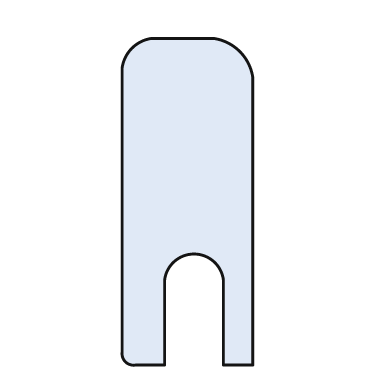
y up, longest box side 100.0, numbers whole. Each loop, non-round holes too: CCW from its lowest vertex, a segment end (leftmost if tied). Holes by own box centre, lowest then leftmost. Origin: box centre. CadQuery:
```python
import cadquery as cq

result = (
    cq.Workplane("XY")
    .moveTo(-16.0, -50.0)
    .lineTo(-7.0, -50.0)
    .lineTo(-7.0, -24.0)
    .threePointArc((2.0, -16.0), (11.0, -24.0))
    .lineTo(11.0, -50.0)
    .lineTo(20.0, -50.0)
    .lineTo(20.0, 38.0)
    .threePointArc((16.0, 46.0), (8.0, 50.0))
    .lineTo(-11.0, 50.0)
    .threePointArc((-17.0, 47.0), (-20.0, 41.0))
    .lineTo(-20.0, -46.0)
    .threePointArc((-19.0, -49.0), (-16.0, -50.0))
    .close()
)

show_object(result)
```